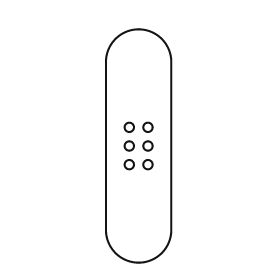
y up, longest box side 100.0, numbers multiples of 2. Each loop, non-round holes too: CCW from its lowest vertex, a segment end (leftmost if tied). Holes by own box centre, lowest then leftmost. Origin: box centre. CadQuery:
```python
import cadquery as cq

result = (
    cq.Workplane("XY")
    .moveTo(-14.0, -36.0)
    .threePointArc((0.0, -50.0), (14.0, -36.0))
    .lineTo(14.0, 36.0)
    .threePointArc((0.0, 50.0), (-14.0, 36.0))
    .close()
    .moveTo(-4.0, -8.0)
    .circle(2.0)
    .moveTo(4.0, -8.0)
    .circle(2.0)
    .moveTo(-4.0, 0.0)
    .circle(2.0)
    .moveTo(4.0, 0.0)
    .circle(2.0)
    .moveTo(-4.0, 8.0)
    .circle(2.0)
    .moveTo(4.0, 8.0)
    .circle(2.0)
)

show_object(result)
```